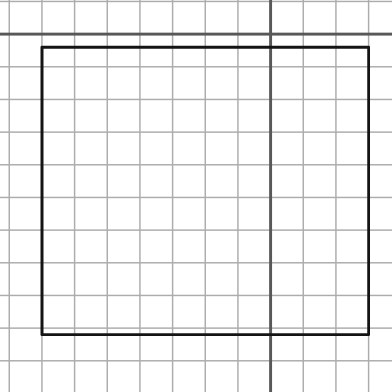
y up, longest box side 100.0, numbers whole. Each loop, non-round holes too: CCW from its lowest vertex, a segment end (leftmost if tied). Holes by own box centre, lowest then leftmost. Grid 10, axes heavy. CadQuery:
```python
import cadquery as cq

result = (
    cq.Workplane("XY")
    .moveTo(-70.0, -92.0)
    .lineTo(30.0, -92.0)
    .lineTo(30.0, -4.0)
    .lineTo(-70.0, -4.0)
    .close()
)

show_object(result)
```